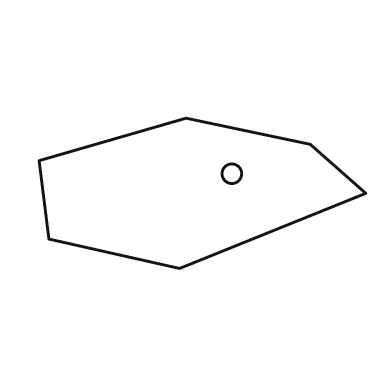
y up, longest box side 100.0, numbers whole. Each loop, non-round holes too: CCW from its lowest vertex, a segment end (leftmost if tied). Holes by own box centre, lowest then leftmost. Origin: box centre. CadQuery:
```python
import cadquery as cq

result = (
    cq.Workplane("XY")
    .moveTo(-7.0, -23.0)
    .lineTo(50.0, 0.0)
    .lineTo(33.0, 15.0)
    .lineTo(-5.0, 23.0)
    .lineTo(-50.0, 10.0)
    .lineTo(-47.0, -14.0)
    .close()
    .moveTo(9.0, 6.0)
    .circle(3.0)
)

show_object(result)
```